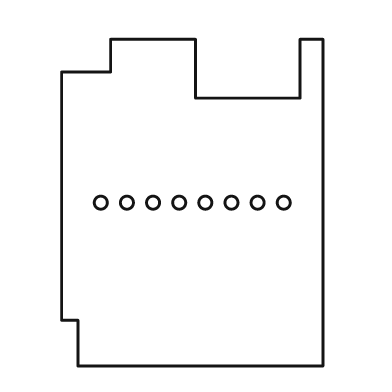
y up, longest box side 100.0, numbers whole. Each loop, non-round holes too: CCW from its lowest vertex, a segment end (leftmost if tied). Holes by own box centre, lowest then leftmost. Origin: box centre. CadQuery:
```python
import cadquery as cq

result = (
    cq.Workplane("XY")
    .moveTo(-35.0, -50.0)
    .lineTo(40.0, -50.0)
    .lineTo(40.0, 50.0)
    .lineTo(33.0, 50.0)
    .lineTo(33.0, 32.0)
    .lineTo(1.0, 32.0)
    .lineTo(1.0, 50.0)
    .lineTo(-25.0, 50.0)
    .lineTo(-25.0, 40.0)
    .lineTo(-40.0, 40.0)
    .lineTo(-40.0, -36.0)
    .lineTo(-35.0, -36.0)
    .close()
    .moveTo(-28.0, 0.0)
    .circle(2.0)
    .moveTo(-20.0, 0.0)
    .circle(2.0)
    .moveTo(-12.0, 0.0)
    .circle(2.0)
    .moveTo(-4.0, 0.0)
    .circle(2.0)
    .moveTo(4.0, 0.0)
    .circle(2.0)
    .moveTo(12.0, 0.0)
    .circle(2.0)
    .moveTo(20.0, 0.0)
    .circle(2.0)
    .moveTo(28.0, 0.0)
    .circle(2.0)
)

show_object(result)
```